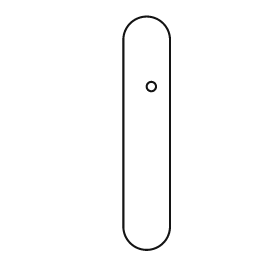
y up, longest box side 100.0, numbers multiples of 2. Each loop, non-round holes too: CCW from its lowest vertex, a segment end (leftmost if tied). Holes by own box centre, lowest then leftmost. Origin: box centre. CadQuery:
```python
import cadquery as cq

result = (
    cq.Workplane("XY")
    .moveTo(-10.0, -40.0)
    .threePointArc((0.0, -50.0), (10.0, -40.0))
    .lineTo(10.0, 40.0)
    .threePointArc((0.0, 50.0), (-10.0, 40.0))
    .close()
    .moveTo(2.0, 20.0)
    .circle(2.0)
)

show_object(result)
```